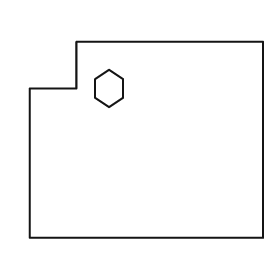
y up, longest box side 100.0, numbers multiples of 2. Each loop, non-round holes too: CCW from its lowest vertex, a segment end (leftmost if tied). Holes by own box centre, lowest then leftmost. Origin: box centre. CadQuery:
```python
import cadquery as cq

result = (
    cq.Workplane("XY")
    .moveTo(-50.0, -42.0)
    .lineTo(50.0, -42.0)
    .lineTo(50.0, 42.0)
    .lineTo(-30.0, 42.0)
    .lineTo(-30.0, 22.0)
    .lineTo(-50.0, 22.0)
    .close()
    .moveTo(-16.0, 14.0)
    .lineTo(-10.0, 18.0)
    .lineTo(-10.0, 26.0)
    .lineTo(-16.0, 30.0)
    .lineTo(-22.0, 26.0)
    .lineTo(-22.0, 18.0)
    .close()
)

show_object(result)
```